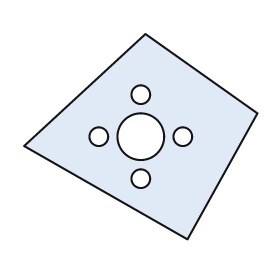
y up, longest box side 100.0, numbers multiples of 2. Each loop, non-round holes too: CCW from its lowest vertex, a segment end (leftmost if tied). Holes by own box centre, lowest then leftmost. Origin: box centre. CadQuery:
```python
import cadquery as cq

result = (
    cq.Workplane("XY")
    .moveTo(20.0, -44.0)
    .lineTo(50.0, 10.0)
    .lineTo(2.0, 44.0)
    .lineTo(-50.0, -4.0)
    .close()
    .moveTo(0.0, -18.0)
    .circle(4.0)
    .moveTo(-18.0, 0.0)
    .circle(4.0)
    .moveTo(0.0, 0.0)
    .circle(10.0)
    .moveTo(18.0, 0.0)
    .circle(4.0)
    .moveTo(0.0, 18.0)
    .circle(4.0)
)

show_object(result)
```